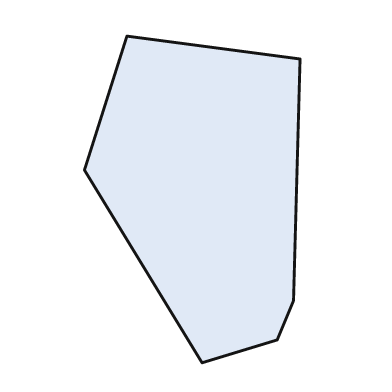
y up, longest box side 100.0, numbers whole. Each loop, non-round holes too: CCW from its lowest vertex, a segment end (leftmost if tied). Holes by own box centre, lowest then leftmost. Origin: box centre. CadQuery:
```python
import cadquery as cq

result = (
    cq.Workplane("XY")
    .moveTo(3.0, -50.0)
    .lineTo(26.0, -43.0)
    .lineTo(31.0, -31.0)
    .lineTo(33.0, 43.0)
    .lineTo(-20.0, 50.0)
    .lineTo(-33.0, 9.0)
    .close()
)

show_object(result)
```